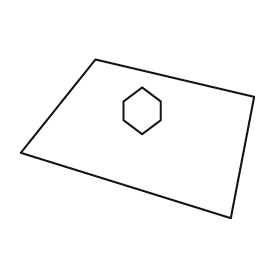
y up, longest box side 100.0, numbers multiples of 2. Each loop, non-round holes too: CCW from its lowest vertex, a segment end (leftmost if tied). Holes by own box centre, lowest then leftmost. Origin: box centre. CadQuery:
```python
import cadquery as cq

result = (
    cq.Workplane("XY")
    .moveTo(40.0, -34.0)
    .lineTo(50.0, 18.0)
    .lineTo(-18.0, 34.0)
    .lineTo(-50.0, -6.0)
    .close()
    .moveTo(2.0, 2.0)
    .lineTo(10.0, 8.0)
    .lineTo(10.0, 16.0)
    .lineTo(2.0, 22.0)
    .lineTo(-6.0, 16.0)
    .lineTo(-6.0, 8.0)
    .close()
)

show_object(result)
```